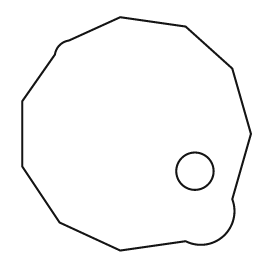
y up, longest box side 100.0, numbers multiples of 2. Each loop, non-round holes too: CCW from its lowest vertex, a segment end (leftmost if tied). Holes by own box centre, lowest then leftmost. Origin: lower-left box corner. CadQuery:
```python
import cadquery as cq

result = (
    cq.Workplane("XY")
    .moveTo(42.0, 0.0)
    .lineTo(70.0, 4.0)
    .threePointArc((86.0, 6.0), (90.0, 22.0))
    .lineTo(98.0, 50.0)
    .lineTo(90.0, 78.0)
    .lineTo(70.0, 96.0)
    .lineTo(42.0, 100.0)
    .lineTo(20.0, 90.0)
    .threePointArc((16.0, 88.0), (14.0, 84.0))
    .lineTo(0.0, 64.0)
    .lineTo(0.0, 36.0)
    .lineTo(16.0, 12.0)
    .close()
    .moveTo(74.0, 34.0)
    .circle(8.0)
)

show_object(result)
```